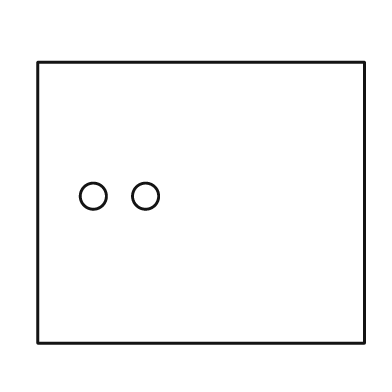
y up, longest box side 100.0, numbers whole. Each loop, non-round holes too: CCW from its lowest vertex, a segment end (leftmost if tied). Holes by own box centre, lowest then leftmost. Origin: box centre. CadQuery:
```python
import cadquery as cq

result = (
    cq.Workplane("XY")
    .moveTo(-50.0, -43.0)
    .lineTo(50.0, -43.0)
    .lineTo(50.0, 43.0)
    .lineTo(-50.0, 43.0)
    .close()
    .moveTo(-33.0, 2.0)
    .circle(4.0)
    .moveTo(-17.0, 2.0)
    .circle(4.0)
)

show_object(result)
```